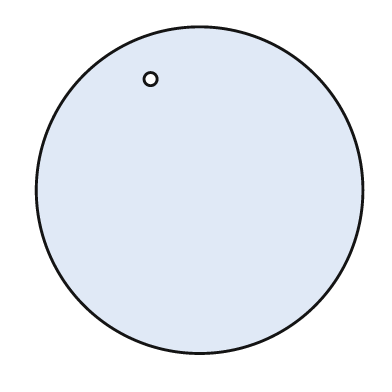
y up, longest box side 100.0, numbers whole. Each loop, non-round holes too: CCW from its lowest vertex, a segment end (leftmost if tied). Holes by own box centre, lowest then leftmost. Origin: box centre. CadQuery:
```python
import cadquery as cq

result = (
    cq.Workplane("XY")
    .moveTo(0.0, 0.0)
    .circle(50.0)
    .moveTo(-15.0, 34.0)
    .circle(2.0)
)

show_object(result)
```